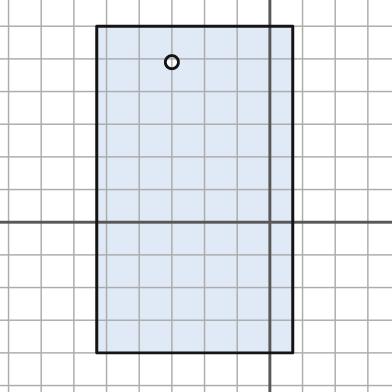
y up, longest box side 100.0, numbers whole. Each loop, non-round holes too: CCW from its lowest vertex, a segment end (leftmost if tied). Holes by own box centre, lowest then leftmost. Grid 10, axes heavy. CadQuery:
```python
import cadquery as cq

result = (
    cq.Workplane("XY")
    .moveTo(-53.0, -40.0)
    .lineTo(7.0, -40.0)
    .lineTo(7.0, 60.0)
    .lineTo(-53.0, 60.0)
    .close()
    .moveTo(-30.0, 49.0)
    .circle(2.0)
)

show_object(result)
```